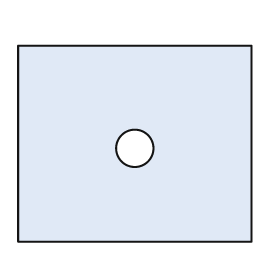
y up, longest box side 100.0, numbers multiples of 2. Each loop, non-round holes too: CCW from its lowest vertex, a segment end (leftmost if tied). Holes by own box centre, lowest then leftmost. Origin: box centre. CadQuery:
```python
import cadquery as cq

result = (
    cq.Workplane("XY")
    .moveTo(-50.0, -42.0)
    .lineTo(50.0, -42.0)
    .lineTo(50.0, 42.0)
    .lineTo(-50.0, 42.0)
    .close()
    .moveTo(0.0, -2.0)
    .circle(8.0)
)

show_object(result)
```